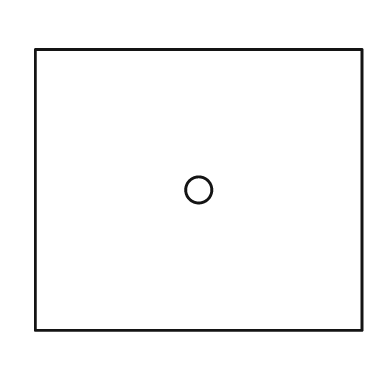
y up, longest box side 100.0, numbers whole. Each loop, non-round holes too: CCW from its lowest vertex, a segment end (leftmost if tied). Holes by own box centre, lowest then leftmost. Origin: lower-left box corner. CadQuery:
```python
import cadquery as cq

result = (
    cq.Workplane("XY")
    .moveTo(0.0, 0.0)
    .lineTo(100.0, 0.0)
    .lineTo(100.0, 86.0)
    .lineTo(0.0, 86.0)
    .close()
    .moveTo(50.0, 43.0)
    .circle(4.0)
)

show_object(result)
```